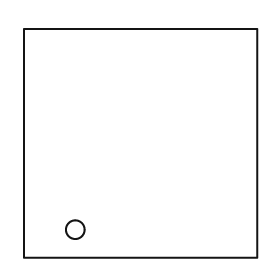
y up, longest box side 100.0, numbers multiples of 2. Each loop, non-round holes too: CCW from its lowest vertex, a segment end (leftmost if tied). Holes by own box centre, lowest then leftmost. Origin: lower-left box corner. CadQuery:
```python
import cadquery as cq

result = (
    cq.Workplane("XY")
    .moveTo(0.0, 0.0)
    .lineTo(100.0, 0.0)
    .lineTo(100.0, 98.0)
    .lineTo(0.0, 98.0)
    .close()
    .moveTo(22.0, 12.0)
    .circle(4.0)
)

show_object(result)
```